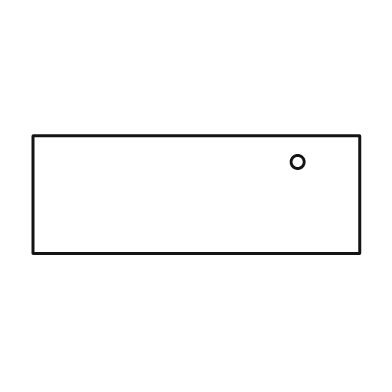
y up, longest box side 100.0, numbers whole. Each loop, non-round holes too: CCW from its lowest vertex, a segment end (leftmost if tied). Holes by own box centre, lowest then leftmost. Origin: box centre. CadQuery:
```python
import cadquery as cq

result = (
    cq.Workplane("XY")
    .moveTo(-50.0, -18.0)
    .lineTo(50.0, -18.0)
    .lineTo(50.0, 18.0)
    .lineTo(-50.0, 18.0)
    .close()
    .moveTo(31.0, 10.0)
    .circle(2.0)
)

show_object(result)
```